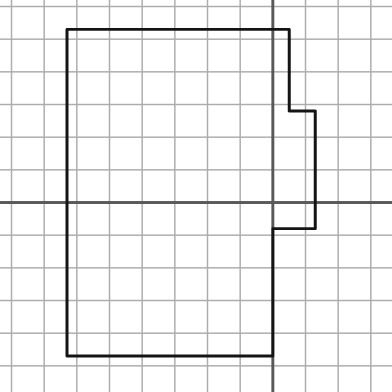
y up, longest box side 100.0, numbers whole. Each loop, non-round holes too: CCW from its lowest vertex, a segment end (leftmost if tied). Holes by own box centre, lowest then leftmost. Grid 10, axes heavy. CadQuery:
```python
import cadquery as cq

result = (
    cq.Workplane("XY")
    .moveTo(-63.0, -47.0)
    .lineTo(0.0, -47.0)
    .lineTo(0.0, -8.0)
    .lineTo(13.0, -8.0)
    .lineTo(13.0, 28.0)
    .lineTo(5.0, 28.0)
    .lineTo(5.0, 53.0)
    .lineTo(-63.0, 53.0)
    .close()
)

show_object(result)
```